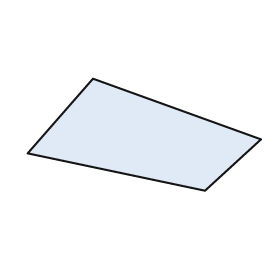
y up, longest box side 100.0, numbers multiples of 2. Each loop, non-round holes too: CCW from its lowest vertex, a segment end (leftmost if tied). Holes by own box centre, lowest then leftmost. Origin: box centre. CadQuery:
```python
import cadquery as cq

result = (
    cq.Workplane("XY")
    .moveTo(26.0, -24.0)
    .lineTo(50.0, -2.0)
    .lineTo(-22.0, 24.0)
    .lineTo(-50.0, -8.0)
    .close()
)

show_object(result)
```